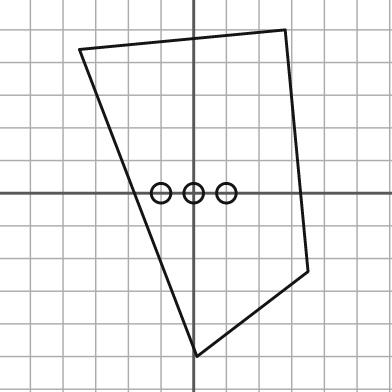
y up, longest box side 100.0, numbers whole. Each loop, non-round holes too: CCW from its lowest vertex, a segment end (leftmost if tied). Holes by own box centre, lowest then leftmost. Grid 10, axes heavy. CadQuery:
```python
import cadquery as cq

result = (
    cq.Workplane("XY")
    .moveTo(1.0, -50.0)
    .lineTo(35.0, -24.0)
    .lineTo(28.0, 50.0)
    .lineTo(-35.0, 44.0)
    .close()
    .moveTo(-10.0, 0.0)
    .circle(3.0)
    .moveTo(0.0, 0.0)
    .circle(3.0)
    .moveTo(10.0, 0.0)
    .circle(3.0)
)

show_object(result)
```